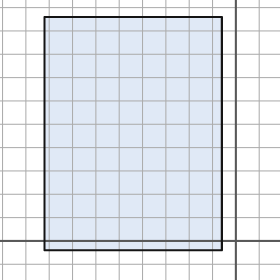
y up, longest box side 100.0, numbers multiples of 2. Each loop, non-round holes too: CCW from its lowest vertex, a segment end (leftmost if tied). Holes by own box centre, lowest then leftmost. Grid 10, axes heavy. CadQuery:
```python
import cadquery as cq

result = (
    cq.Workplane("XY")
    .moveTo(-82.0, -4.0)
    .lineTo(-6.0, -4.0)
    .lineTo(-6.0, 96.0)
    .lineTo(-82.0, 96.0)
    .close()
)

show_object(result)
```